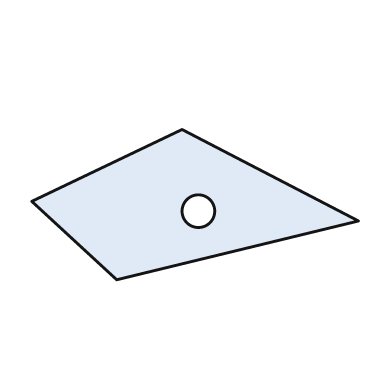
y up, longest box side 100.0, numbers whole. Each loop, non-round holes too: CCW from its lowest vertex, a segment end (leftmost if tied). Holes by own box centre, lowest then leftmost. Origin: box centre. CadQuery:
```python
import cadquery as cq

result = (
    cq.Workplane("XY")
    .moveTo(-24.0, -23.0)
    .lineTo(50.0, -5.0)
    .lineTo(-4.0, 23.0)
    .lineTo(-50.0, 1.0)
    .close()
    .moveTo(1.0, -2.0)
    .circle(5.0)
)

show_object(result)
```